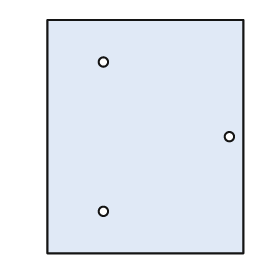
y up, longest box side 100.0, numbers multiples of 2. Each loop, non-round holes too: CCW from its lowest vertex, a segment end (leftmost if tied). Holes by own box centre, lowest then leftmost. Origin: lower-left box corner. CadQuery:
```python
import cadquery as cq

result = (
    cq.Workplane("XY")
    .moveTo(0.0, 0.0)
    .lineTo(84.0, 0.0)
    .lineTo(84.0, 100.0)
    .lineTo(0.0, 100.0)
    .close()
    .moveTo(24.0, 18.0)
    .circle(2.0)
    .moveTo(78.0, 50.0)
    .circle(2.0)
    .moveTo(24.0, 82.0)
    .circle(2.0)
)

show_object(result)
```